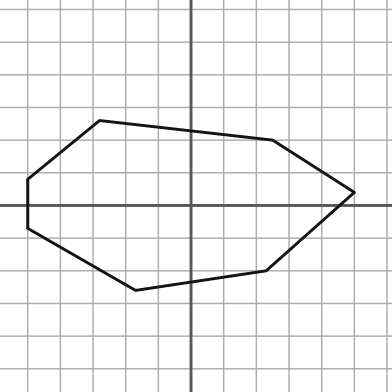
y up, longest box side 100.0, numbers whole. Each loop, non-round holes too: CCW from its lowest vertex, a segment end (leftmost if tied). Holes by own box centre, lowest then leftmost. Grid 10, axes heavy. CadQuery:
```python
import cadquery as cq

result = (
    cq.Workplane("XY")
    .moveTo(-17.0, -26.0)
    .lineTo(23.0, -20.0)
    .lineTo(50.0, 4.0)
    .lineTo(25.0, 20.0)
    .lineTo(-28.0, 26.0)
    .lineTo(-50.0, 8.0)
    .lineTo(-50.0, -7.0)
    .close()
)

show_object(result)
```